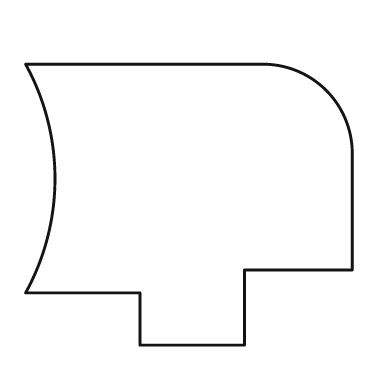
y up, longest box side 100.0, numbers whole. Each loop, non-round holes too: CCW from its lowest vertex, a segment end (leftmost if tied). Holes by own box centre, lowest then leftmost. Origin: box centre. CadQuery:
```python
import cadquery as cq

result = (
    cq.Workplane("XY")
    .moveTo(-15.0, -43.0)
    .lineTo(17.0, -43.0)
    .lineTo(17.0, -20.0)
    .lineTo(50.0, -20.0)
    .lineTo(50.0, 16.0)
    .threePointArc((42.0, 35.0), (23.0, 43.0))
    .lineTo(-50.0, 43.0)
    .threePointArc((-41.0, 8.0), (-50.0, -27.0))
    .lineTo(-15.0, -27.0)
    .close()
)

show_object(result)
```